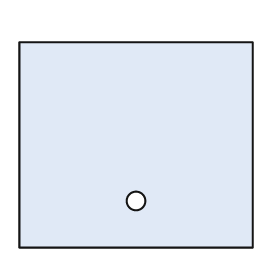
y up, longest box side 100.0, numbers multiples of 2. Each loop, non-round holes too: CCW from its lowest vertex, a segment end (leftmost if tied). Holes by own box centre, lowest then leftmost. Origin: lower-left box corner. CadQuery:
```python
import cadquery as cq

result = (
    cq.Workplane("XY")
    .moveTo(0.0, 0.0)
    .lineTo(100.0, 0.0)
    .lineTo(100.0, 88.0)
    .lineTo(0.0, 88.0)
    .close()
    .moveTo(50.0, 20.0)
    .circle(4.0)
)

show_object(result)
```